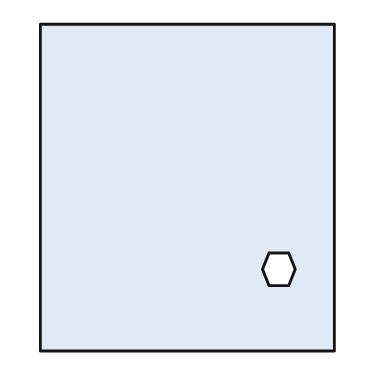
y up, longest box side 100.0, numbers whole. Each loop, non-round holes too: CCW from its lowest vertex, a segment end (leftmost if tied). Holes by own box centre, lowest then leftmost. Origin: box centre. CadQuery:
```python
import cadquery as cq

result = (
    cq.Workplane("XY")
    .moveTo(-45.0, -50.0)
    .lineTo(45.0, -50.0)
    .lineTo(45.0, 50.0)
    .lineTo(-45.0, 50.0)
    .close()
    .moveTo(25.0, -30.0)
    .lineTo(31.0, -30.0)
    .lineTo(33.0, -25.0)
    .lineTo(31.0, -20.0)
    .lineTo(25.0, -20.0)
    .lineTo(23.0, -25.0)
    .close()
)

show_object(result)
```